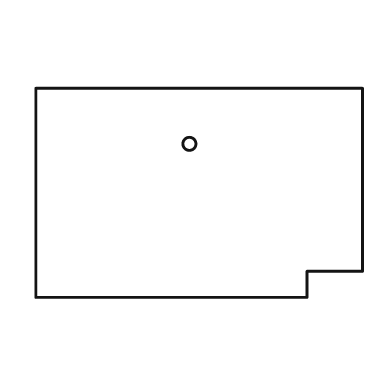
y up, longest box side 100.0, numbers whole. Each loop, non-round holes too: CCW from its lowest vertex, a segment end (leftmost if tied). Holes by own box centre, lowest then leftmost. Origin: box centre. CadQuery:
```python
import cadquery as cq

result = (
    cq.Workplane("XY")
    .moveTo(-50.0, -32.0)
    .lineTo(33.0, -32.0)
    .lineTo(33.0, -24.0)
    .lineTo(50.0, -24.0)
    .lineTo(50.0, 32.0)
    .lineTo(-50.0, 32.0)
    .close()
    .moveTo(-3.0, 15.0)
    .circle(2.0)
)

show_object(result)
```